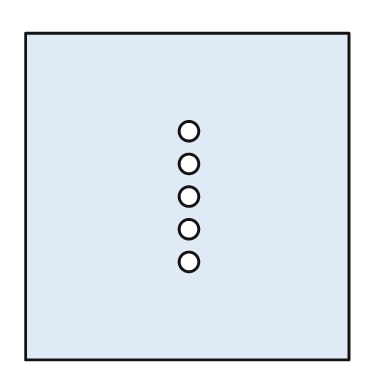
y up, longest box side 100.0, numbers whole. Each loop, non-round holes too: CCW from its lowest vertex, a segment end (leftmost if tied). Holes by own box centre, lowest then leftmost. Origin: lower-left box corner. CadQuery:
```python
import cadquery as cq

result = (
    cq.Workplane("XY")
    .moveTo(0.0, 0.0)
    .lineTo(99.0, 0.0)
    .lineTo(99.0, 100.0)
    .lineTo(0.0, 100.0)
    .close()
    .moveTo(50.0, 30.0)
    .circle(3.0)
    .moveTo(50.0, 40.0)
    .circle(3.0)
    .moveTo(50.0, 50.0)
    .circle(3.0)
    .moveTo(50.0, 60.0)
    .circle(3.0)
    .moveTo(50.0, 70.0)
    .circle(3.0)
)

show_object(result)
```